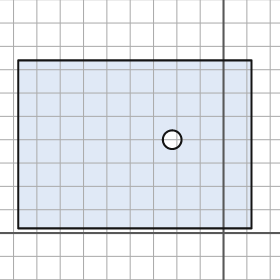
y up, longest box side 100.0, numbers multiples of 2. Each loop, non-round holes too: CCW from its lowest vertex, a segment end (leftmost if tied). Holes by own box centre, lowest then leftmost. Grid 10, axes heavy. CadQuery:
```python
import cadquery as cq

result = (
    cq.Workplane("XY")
    .moveTo(-88.0, 2.0)
    .lineTo(12.0, 2.0)
    .lineTo(12.0, 74.0)
    .lineTo(-88.0, 74.0)
    .close()
    .moveTo(-22.0, 40.0)
    .circle(4.0)
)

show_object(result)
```